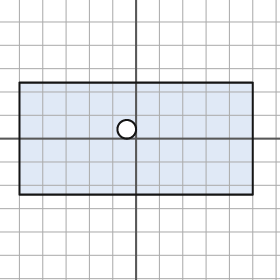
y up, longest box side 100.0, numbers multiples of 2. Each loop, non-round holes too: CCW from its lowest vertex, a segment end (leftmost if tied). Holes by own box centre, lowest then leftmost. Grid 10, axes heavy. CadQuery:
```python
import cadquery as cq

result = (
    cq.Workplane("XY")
    .moveTo(-50.0, -24.0)
    .lineTo(50.0, -24.0)
    .lineTo(50.0, 24.0)
    .lineTo(-50.0, 24.0)
    .close()
    .moveTo(-4.0, 4.0)
    .circle(4.0)
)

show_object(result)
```